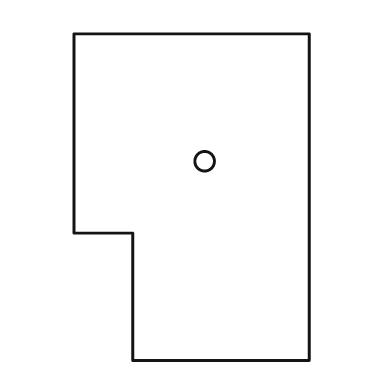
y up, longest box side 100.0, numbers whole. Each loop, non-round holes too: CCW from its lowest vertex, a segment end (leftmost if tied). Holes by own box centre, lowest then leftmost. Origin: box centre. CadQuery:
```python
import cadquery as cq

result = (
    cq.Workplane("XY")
    .moveTo(-18.0, -50.0)
    .lineTo(36.0, -50.0)
    .lineTo(36.0, 50.0)
    .lineTo(-36.0, 50.0)
    .lineTo(-36.0, -11.0)
    .lineTo(-18.0, -11.0)
    .close()
    .moveTo(4.0, 11.0)
    .circle(3.0)
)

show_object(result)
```